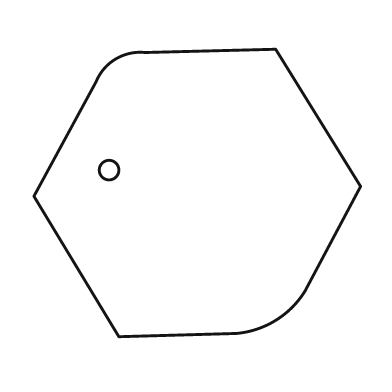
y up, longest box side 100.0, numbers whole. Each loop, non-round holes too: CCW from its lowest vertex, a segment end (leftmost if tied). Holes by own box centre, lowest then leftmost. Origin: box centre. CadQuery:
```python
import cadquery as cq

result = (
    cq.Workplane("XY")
    .moveTo(-24.0, -44.0)
    .lineTo(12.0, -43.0)
    .threePointArc((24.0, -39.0), (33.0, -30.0))
    .lineTo(50.0, 2.0)
    .lineTo(24.0, 44.0)
    .lineTo(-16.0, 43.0)
    .threePointArc((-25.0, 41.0), (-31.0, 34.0))
    .lineTo(-50.0, -1.0)
    .close()
    .moveTo(-27.0, 7.0)
    .circle(3.0)
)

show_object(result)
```